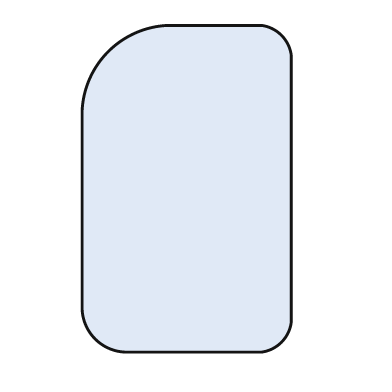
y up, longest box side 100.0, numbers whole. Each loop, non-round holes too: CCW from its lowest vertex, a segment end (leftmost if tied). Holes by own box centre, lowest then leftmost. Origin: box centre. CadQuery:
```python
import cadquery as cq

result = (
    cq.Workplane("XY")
    .moveTo(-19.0, -50.0)
    .lineTo(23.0, -50.0)
    .threePointArc((29.0, -47.0), (32.0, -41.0))
    .lineTo(32.0, 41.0)
    .threePointArc((29.0, 47.0), (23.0, 50.0))
    .lineTo(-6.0, 50.0)
    .threePointArc((-24.0, 42.0), (-32.0, 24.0))
    .lineTo(-32.0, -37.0)
    .threePointArc((-28.0, -46.0), (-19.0, -50.0))
    .close()
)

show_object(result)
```